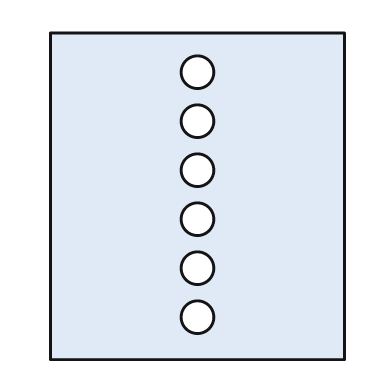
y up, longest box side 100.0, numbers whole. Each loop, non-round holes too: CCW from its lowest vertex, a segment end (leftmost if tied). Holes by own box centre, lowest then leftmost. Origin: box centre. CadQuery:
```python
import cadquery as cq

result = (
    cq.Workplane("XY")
    .moveTo(-45.0, -50.0)
    .lineTo(45.0, -50.0)
    .lineTo(45.0, 50.0)
    .lineTo(-45.0, 50.0)
    .close()
    .moveTo(0.0, -37.0)
    .circle(5.0)
    .moveTo(0.0, -22.0)
    .circle(5.0)
    .moveTo(0.0, -7.0)
    .circle(5.0)
    .moveTo(0.0, 8.0)
    .circle(5.0)
    .moveTo(0.0, 23.0)
    .circle(5.0)
    .moveTo(0.0, 38.0)
    .circle(5.0)
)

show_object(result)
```